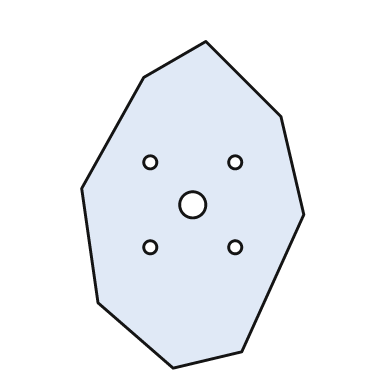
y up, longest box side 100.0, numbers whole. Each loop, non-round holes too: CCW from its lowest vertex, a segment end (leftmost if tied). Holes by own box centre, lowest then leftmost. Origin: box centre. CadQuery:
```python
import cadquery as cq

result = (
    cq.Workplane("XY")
    .moveTo(-6.0, -50.0)
    .lineTo(15.0, -45.0)
    .lineTo(34.0, -3.0)
    .lineTo(27.0, 27.0)
    .lineTo(4.0, 50.0)
    .lineTo(-15.0, 39.0)
    .lineTo(-34.0, 5.0)
    .lineTo(-29.0, -30.0)
    .close()
    .moveTo(-13.0, -13.0)
    .circle(2.0)
    .moveTo(13.0, -13.0)
    .circle(2.0)
    .moveTo(0.0, 0.0)
    .circle(4.0)
    .moveTo(-13.0, 13.0)
    .circle(2.0)
    .moveTo(13.0, 13.0)
    .circle(2.0)
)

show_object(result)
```